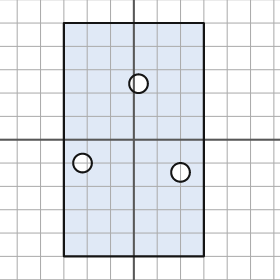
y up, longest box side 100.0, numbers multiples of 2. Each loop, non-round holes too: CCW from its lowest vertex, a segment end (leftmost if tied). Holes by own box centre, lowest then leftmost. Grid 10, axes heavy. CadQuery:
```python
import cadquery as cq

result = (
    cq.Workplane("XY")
    .moveTo(-30.0, -50.0)
    .lineTo(30.0, -50.0)
    .lineTo(30.0, 50.0)
    .lineTo(-30.0, 50.0)
    .close()
    .moveTo(20.0, -14.0)
    .circle(4.0)
    .moveTo(-22.0, -10.0)
    .circle(4.0)
    .moveTo(2.0, 24.0)
    .circle(4.0)
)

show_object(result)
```